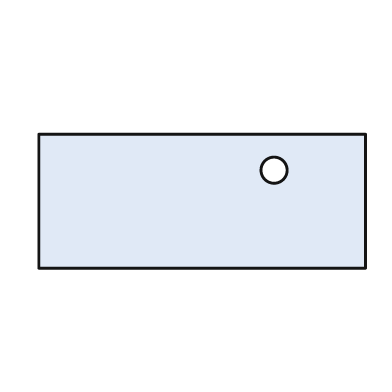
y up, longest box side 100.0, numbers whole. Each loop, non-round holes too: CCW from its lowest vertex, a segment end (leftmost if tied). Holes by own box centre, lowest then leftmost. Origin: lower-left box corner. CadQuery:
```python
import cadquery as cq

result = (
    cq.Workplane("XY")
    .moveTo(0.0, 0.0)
    .lineTo(100.0, 0.0)
    .lineTo(100.0, 41.0)
    .lineTo(0.0, 41.0)
    .close()
    .moveTo(72.0, 30.0)
    .circle(4.0)
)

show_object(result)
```